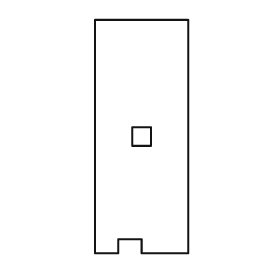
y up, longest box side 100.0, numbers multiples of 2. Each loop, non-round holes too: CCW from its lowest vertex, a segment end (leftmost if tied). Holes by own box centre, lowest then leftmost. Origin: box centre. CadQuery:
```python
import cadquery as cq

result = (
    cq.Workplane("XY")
    .moveTo(-20.0, -50.0)
    .lineTo(-10.0, -50.0)
    .lineTo(-10.0, -44.0)
    .lineTo(0.0, -44.0)
    .lineTo(0.0, -50.0)
    .lineTo(20.0, -50.0)
    .lineTo(20.0, 50.0)
    .lineTo(-20.0, 50.0)
    .close()
    .moveTo(-4.0, -4.0)
    .lineTo(4.0, -4.0)
    .lineTo(4.0, 4.0)
    .lineTo(-4.0, 4.0)
    .close()
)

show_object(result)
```